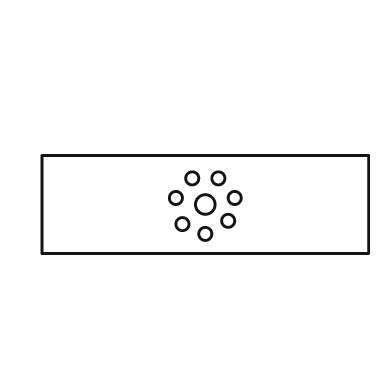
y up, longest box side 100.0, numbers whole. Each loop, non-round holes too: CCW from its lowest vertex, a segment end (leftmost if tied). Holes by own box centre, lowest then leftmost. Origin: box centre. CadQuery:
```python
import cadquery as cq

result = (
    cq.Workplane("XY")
    .moveTo(-50.0, -15.0)
    .lineTo(50.0, -15.0)
    .lineTo(50.0, 15.0)
    .lineTo(-50.0, 15.0)
    .close()
    .moveTo(0.0, -9.0)
    .circle(2.0)
    .moveTo(-7.0, -6.0)
    .circle(2.0)
    .moveTo(7.0, -5.0)
    .circle(2.0)
    .moveTo(0.0, 0.0)
    .circle(3.0)
    .moveTo(-9.0, 2.0)
    .circle(2.0)
    .moveTo(9.0, 2.0)
    .circle(2.0)
    .moveTo(-4.0, 8.0)
    .circle(2.0)
    .moveTo(4.0, 8.0)
    .circle(2.0)
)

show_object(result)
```